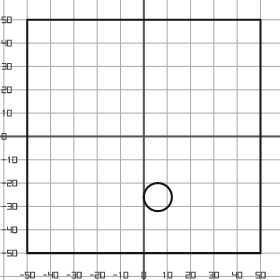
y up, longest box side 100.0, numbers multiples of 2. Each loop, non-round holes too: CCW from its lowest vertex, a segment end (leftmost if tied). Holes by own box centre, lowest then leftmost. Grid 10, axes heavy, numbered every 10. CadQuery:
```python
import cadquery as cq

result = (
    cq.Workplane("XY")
    .moveTo(-50.0, -50.0)
    .lineTo(50.0, -50.0)
    .lineTo(50.0, 50.0)
    .lineTo(-50.0, 50.0)
    .close()
    .moveTo(6.0, -26.0)
    .circle(6.0)
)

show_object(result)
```